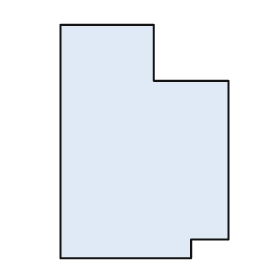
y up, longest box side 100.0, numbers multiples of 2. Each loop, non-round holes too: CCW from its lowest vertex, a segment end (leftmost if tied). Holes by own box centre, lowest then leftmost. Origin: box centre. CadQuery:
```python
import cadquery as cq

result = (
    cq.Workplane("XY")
    .moveTo(-36.0, -50.0)
    .lineTo(20.0, -50.0)
    .lineTo(20.0, -42.0)
    .lineTo(36.0, -42.0)
    .lineTo(36.0, 26.0)
    .lineTo(4.0, 26.0)
    .lineTo(4.0, 50.0)
    .lineTo(-36.0, 50.0)
    .close()
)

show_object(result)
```